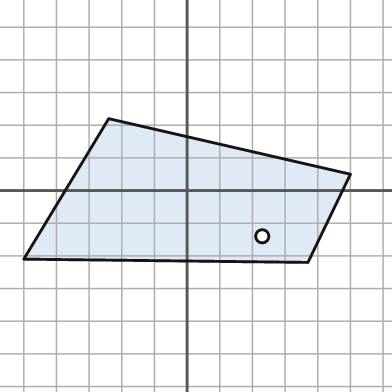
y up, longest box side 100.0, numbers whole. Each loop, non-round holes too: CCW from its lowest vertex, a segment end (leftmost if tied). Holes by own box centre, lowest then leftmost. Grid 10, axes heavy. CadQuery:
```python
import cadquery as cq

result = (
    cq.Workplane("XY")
    .moveTo(37.0, -22.0)
    .lineTo(50.0, 5.0)
    .lineTo(-24.0, 22.0)
    .lineTo(-50.0, -21.0)
    .close()
    .moveTo(23.0, -14.0)
    .circle(2.0)
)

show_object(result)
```